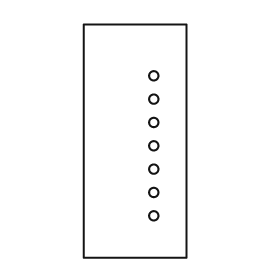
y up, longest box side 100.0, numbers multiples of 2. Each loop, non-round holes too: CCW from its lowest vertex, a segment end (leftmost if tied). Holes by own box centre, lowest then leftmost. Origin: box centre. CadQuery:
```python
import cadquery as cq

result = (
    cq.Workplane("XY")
    .moveTo(-22.0, -50.0)
    .lineTo(22.0, -50.0)
    .lineTo(22.0, 50.0)
    .lineTo(-22.0, 50.0)
    .close()
    .moveTo(8.0, -32.0)
    .circle(2.0)
    .moveTo(8.0, -22.0)
    .circle(2.0)
    .moveTo(8.0, -12.0)
    .circle(2.0)
    .moveTo(8.0, -2.0)
    .circle(2.0)
    .moveTo(8.0, 8.0)
    .circle(2.0)
    .moveTo(8.0, 18.0)
    .circle(2.0)
    .moveTo(8.0, 28.0)
    .circle(2.0)
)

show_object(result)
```